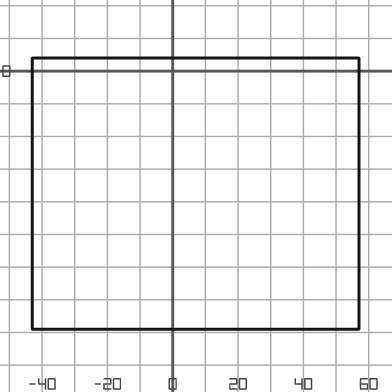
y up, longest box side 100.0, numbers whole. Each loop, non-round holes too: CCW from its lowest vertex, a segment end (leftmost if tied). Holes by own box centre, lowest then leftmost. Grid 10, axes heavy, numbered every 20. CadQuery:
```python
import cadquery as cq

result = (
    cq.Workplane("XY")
    .moveTo(-43.0, -79.0)
    .lineTo(57.0, -79.0)
    .lineTo(57.0, 4.0)
    .lineTo(-43.0, 4.0)
    .close()
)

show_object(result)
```